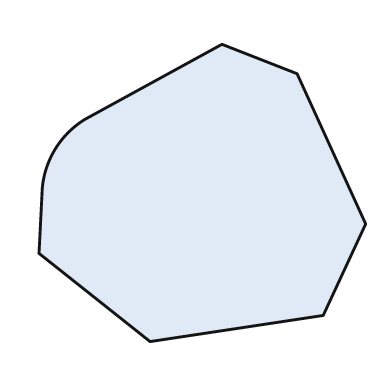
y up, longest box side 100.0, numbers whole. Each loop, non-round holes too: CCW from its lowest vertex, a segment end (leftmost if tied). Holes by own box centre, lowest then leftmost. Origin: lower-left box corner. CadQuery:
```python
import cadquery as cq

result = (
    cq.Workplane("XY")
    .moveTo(34.0, 0.0)
    .lineTo(87.0, 8.0)
    .lineTo(100.0, 36.0)
    .lineTo(79.0, 82.0)
    .lineTo(56.0, 91.0)
    .lineTo(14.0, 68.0)
    .threePointArc((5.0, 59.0), (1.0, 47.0))
    .lineTo(0.0, 27.0)
    .close()
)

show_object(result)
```